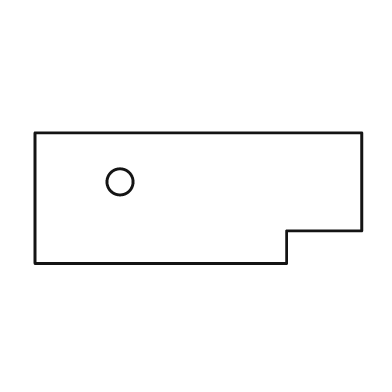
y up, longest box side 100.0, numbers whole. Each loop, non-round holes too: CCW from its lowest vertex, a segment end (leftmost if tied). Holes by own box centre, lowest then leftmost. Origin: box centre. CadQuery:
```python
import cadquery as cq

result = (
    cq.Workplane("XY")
    .moveTo(-50.0, -20.0)
    .lineTo(27.0, -20.0)
    .lineTo(27.0, -10.0)
    .lineTo(50.0, -10.0)
    .lineTo(50.0, 20.0)
    .lineTo(-50.0, 20.0)
    .close()
    .moveTo(-24.0, 5.0)
    .circle(4.0)
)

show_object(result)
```